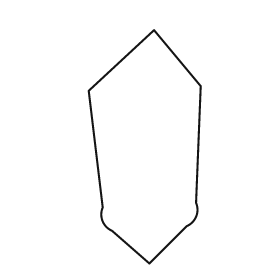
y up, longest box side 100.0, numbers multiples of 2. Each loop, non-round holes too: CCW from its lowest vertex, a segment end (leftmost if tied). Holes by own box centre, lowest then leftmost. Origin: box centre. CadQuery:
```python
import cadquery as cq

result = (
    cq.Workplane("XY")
    .moveTo(2.0, -50.0)
    .lineTo(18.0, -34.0)
    .threePointArc((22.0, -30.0), (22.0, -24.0))
    .lineTo(24.0, 26.0)
    .lineTo(4.0, 50.0)
    .lineTo(-24.0, 24.0)
    .lineTo(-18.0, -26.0)
    .threePointArc((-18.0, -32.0), (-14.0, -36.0))
    .close()
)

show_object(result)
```